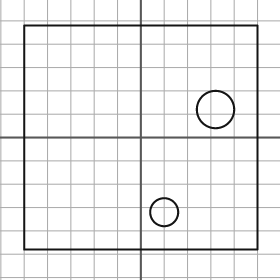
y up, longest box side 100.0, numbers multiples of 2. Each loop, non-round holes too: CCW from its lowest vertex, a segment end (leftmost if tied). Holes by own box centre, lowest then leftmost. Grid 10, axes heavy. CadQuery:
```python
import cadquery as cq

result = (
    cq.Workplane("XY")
    .moveTo(-50.0, -48.0)
    .lineTo(50.0, -48.0)
    .lineTo(50.0, 48.0)
    .lineTo(-50.0, 48.0)
    .close()
    .moveTo(10.0, -32.0)
    .circle(6.0)
    .moveTo(32.0, 12.0)
    .circle(8.0)
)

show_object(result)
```